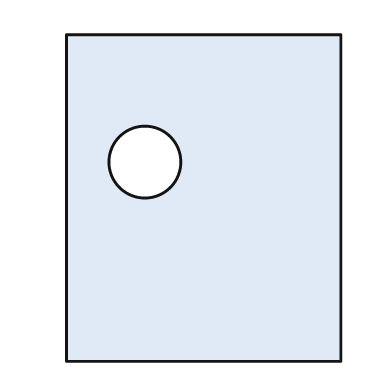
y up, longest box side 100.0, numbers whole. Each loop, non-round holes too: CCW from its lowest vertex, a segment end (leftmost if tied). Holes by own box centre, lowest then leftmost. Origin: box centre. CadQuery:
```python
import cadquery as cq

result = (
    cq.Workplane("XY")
    .moveTo(-42.0, -50.0)
    .lineTo(42.0, -50.0)
    .lineTo(42.0, 50.0)
    .lineTo(-42.0, 50.0)
    .close()
    .moveTo(-18.0, 11.0)
    .circle(11.0)
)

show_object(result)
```